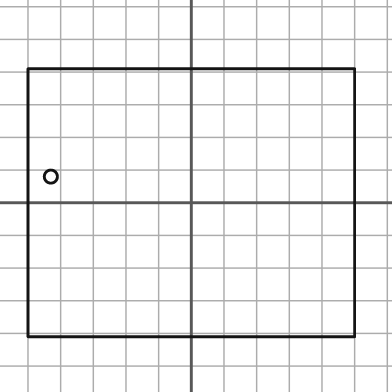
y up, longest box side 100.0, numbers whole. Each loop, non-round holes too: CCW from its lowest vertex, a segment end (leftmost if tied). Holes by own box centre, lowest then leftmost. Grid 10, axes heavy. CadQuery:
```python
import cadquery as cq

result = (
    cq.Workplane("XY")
    .moveTo(-50.0, -41.0)
    .lineTo(50.0, -41.0)
    .lineTo(50.0, 41.0)
    .lineTo(-50.0, 41.0)
    .close()
    .moveTo(-43.0, 8.0)
    .circle(2.0)
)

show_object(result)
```